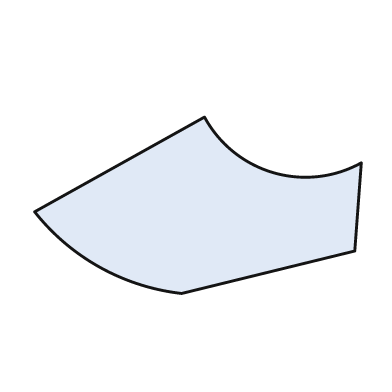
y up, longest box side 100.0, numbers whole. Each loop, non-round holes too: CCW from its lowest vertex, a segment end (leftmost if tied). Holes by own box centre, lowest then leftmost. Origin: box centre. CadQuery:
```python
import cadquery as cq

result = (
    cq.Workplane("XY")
    .moveTo(-5.0, -27.0)
    .lineTo(48.0, -14.0)
    .lineTo(50.0, 13.0)
    .threePointArc((23.0, 10.0), (2.0, 27.0))
    .lineTo(-50.0, -2.0)
    .threePointArc((-30.0, -19.0), (-5.0, -27.0))
    .close()
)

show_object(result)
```